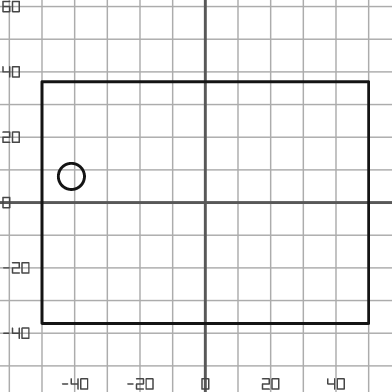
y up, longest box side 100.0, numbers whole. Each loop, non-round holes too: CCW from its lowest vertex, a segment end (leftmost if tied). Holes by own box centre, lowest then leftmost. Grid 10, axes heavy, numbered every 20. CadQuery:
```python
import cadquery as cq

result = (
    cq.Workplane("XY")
    .moveTo(-50.0, -37.0)
    .lineTo(50.0, -37.0)
    .lineTo(50.0, 37.0)
    .lineTo(-50.0, 37.0)
    .close()
    .moveTo(-41.0, 8.0)
    .circle(4.0)
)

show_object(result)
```